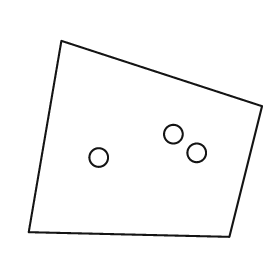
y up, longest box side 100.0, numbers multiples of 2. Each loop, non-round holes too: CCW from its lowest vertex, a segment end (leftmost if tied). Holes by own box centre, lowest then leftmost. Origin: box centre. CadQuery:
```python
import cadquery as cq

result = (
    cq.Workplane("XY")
    .moveTo(36.0, -42.0)
    .lineTo(50.0, 14.0)
    .lineTo(-36.0, 42.0)
    .lineTo(-50.0, -40.0)
    .close()
    .moveTo(-20.0, -8.0)
    .circle(4.0)
    .moveTo(22.0, -6.0)
    .circle(4.0)
    .moveTo(12.0, 2.0)
    .circle(4.0)
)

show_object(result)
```